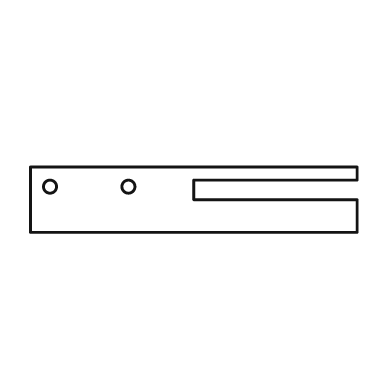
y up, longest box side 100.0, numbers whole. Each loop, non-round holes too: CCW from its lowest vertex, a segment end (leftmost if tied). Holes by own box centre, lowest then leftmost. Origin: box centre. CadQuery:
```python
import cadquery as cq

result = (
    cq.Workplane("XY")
    .moveTo(-50.0, -10.0)
    .lineTo(50.0, -10.0)
    .lineTo(50.0, 0.0)
    .lineTo(0.0, 0.0)
    .lineTo(0.0, 6.0)
    .lineTo(50.0, 6.0)
    .lineTo(50.0, 10.0)
    .lineTo(-50.0, 10.0)
    .close()
    .moveTo(-44.0, 4.0)
    .circle(2.0)
    .moveTo(-20.0, 4.0)
    .circle(2.0)
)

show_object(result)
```